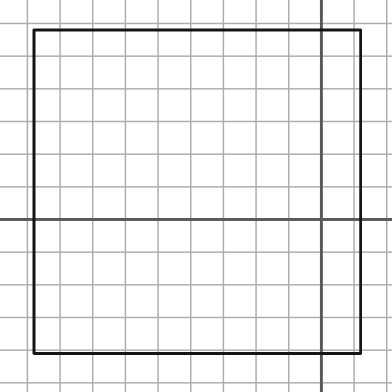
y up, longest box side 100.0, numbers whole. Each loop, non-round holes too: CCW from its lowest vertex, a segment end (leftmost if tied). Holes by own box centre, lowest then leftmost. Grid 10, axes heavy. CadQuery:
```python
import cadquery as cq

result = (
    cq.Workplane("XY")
    .moveTo(-88.0, -41.0)
    .lineTo(12.0, -41.0)
    .lineTo(12.0, 58.0)
    .lineTo(-88.0, 58.0)
    .close()
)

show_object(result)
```